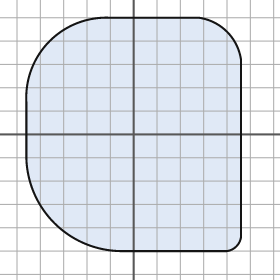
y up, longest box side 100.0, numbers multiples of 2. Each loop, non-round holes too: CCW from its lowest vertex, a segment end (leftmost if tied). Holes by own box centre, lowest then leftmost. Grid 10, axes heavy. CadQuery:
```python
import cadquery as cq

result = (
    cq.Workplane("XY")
    .moveTo(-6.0, -50.0)
    .lineTo(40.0, -50.0)
    .threePointArc((44.0, -48.0), (46.0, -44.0))
    .lineTo(46.0, 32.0)
    .threePointArc((40.0, 44.0), (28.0, 50.0))
    .lineTo(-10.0, 50.0)
    .threePointArc((-36.0, 40.0), (-46.0, 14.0))
    .lineTo(-46.0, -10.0)
    .threePointArc((-34.0, -38.0), (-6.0, -50.0))
    .close()
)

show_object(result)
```